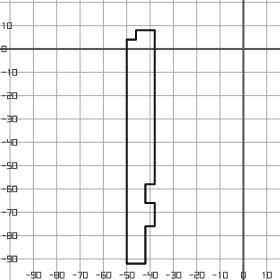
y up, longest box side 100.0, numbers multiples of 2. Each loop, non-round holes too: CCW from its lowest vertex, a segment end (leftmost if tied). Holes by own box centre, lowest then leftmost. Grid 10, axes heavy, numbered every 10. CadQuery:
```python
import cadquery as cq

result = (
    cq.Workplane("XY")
    .moveTo(-50.0, -92.0)
    .lineTo(-42.0, -92.0)
    .lineTo(-42.0, -76.0)
    .lineTo(-38.0, -76.0)
    .lineTo(-38.0, -66.0)
    .lineTo(-42.0, -66.0)
    .lineTo(-42.0, -58.0)
    .lineTo(-38.0, -58.0)
    .lineTo(-38.0, 8.0)
    .lineTo(-46.0, 8.0)
    .lineTo(-46.0, 4.0)
    .lineTo(-50.0, 4.0)
    .close()
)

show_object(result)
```